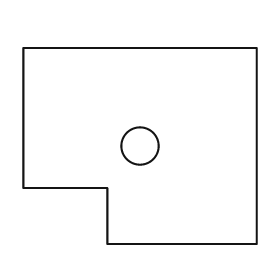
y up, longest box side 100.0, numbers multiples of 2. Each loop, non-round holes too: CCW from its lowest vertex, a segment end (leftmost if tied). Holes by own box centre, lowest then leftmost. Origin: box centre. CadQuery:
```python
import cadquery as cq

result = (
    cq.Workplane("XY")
    .moveTo(-14.0, -42.0)
    .lineTo(50.0, -42.0)
    .lineTo(50.0, 42.0)
    .lineTo(-50.0, 42.0)
    .lineTo(-50.0, -18.0)
    .lineTo(-14.0, -18.0)
    .close()
    .moveTo(0.0, 0.0)
    .circle(8.0)
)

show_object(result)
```